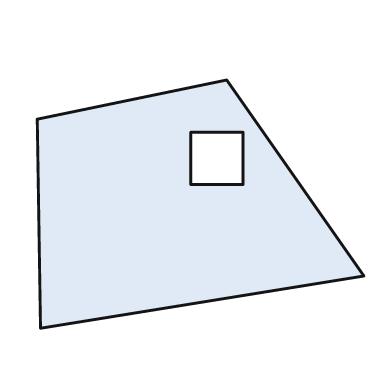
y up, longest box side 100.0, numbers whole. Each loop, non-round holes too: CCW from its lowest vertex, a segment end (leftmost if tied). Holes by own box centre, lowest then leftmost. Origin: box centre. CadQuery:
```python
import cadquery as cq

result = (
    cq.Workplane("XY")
    .moveTo(-49.0, -38.0)
    .lineTo(50.0, -22.0)
    .lineTo(8.0, 38.0)
    .lineTo(-50.0, 26.0)
    .close()
    .moveTo(-3.0, 6.0)
    .lineTo(13.0, 6.0)
    .lineTo(13.0, 22.0)
    .lineTo(-3.0, 22.0)
    .close()
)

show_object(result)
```